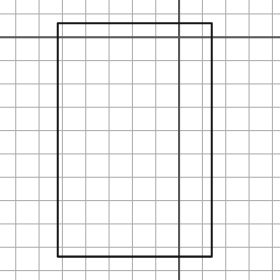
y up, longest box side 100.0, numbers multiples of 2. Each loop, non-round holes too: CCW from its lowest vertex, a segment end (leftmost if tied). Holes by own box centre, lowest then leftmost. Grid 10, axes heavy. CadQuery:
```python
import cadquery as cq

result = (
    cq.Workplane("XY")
    .moveTo(-52.0, -94.0)
    .lineTo(14.0, -94.0)
    .lineTo(14.0, 6.0)
    .lineTo(-52.0, 6.0)
    .close()
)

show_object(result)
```